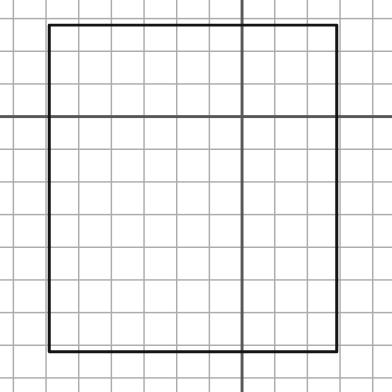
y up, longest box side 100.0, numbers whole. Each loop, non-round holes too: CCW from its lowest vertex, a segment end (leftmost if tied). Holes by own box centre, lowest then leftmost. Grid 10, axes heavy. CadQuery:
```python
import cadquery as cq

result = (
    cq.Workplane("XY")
    .moveTo(-59.0, -72.0)
    .lineTo(29.0, -72.0)
    .lineTo(29.0, 28.0)
    .lineTo(-59.0, 28.0)
    .close()
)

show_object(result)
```